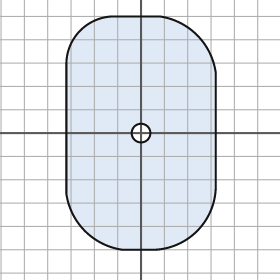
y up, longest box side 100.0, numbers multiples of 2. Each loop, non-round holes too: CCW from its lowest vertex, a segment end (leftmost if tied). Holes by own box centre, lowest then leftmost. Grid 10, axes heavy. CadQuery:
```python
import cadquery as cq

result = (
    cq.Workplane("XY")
    .moveTo(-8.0, -50.0)
    .lineTo(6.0, -50.0)
    .threePointArc((24.0, -42.0), (32.0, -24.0))
    .lineTo(32.0, 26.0)
    .threePointArc((24.0, 42.0), (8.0, 50.0))
    .lineTo(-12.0, 50.0)
    .threePointArc((-26.0, 44.0), (-32.0, 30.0))
    .lineTo(-32.0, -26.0)
    .threePointArc((-24.0, -42.0), (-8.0, -50.0))
    .close()
    .moveTo(0.0, 0.0)
    .circle(4.0)
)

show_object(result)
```